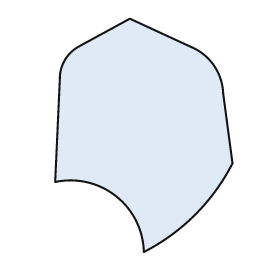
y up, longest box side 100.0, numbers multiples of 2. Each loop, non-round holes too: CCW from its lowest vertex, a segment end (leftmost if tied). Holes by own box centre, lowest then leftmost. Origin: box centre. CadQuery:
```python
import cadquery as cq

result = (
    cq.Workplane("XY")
    .moveTo(0.0, -50.0)
    .threePointArc((22.0, -34.0), (38.0, -12.0))
    .lineTo(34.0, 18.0)
    .threePointArc((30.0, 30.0), (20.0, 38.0))
    .lineTo(-6.0, 50.0)
    .lineTo(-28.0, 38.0)
    .threePointArc((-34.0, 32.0), (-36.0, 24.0))
    .lineTo(-38.0, -20.0)
    .threePointArc((-12.0, -26.0), (0.0, -50.0))
    .close()
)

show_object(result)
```